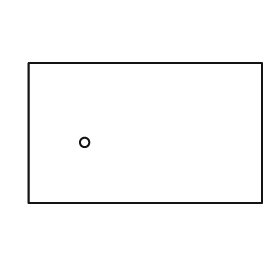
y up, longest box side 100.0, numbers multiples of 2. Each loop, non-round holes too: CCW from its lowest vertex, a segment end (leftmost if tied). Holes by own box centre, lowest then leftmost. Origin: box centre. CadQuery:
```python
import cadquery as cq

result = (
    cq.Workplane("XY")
    .moveTo(-50.0, -30.0)
    .lineTo(50.0, -30.0)
    .lineTo(50.0, 30.0)
    .lineTo(-50.0, 30.0)
    .close()
    .moveTo(-26.0, -4.0)
    .circle(2.0)
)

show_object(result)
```